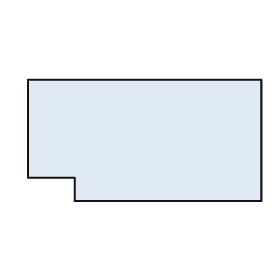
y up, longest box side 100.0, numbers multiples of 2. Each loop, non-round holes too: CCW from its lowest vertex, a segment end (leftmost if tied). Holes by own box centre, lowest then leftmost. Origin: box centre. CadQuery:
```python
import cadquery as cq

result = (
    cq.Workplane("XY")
    .moveTo(-30.0, -26.0)
    .lineTo(50.0, -26.0)
    .lineTo(50.0, 26.0)
    .lineTo(-50.0, 26.0)
    .lineTo(-50.0, -16.0)
    .lineTo(-30.0, -16.0)
    .close()
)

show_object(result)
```